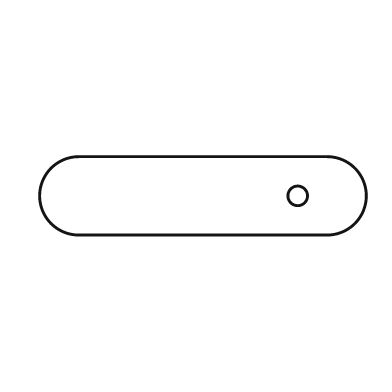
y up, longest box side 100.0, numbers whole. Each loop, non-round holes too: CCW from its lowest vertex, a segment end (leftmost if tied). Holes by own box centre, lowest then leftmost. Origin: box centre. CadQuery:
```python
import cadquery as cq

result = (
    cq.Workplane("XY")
    .moveTo(-38.0, -12.0)
    .lineTo(38.0, -12.0)
    .threePointArc((50.0, 0.0), (38.0, 12.0))
    .lineTo(-38.0, 12.0)
    .threePointArc((-50.0, 0.0), (-38.0, -12.0))
    .close()
    .moveTo(29.0, 0.0)
    .circle(3.0)
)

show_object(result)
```